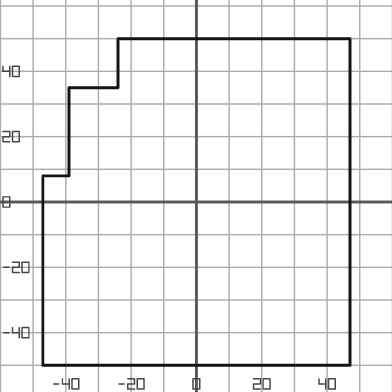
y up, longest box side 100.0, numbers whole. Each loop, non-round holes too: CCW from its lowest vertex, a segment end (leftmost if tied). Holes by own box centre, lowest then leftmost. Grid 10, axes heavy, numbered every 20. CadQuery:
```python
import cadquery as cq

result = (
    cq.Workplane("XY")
    .moveTo(-47.0, -50.0)
    .lineTo(47.0, -50.0)
    .lineTo(47.0, 50.0)
    .lineTo(-24.0, 50.0)
    .lineTo(-24.0, 35.0)
    .lineTo(-39.0, 35.0)
    .lineTo(-39.0, 8.0)
    .lineTo(-47.0, 8.0)
    .close()
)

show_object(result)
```